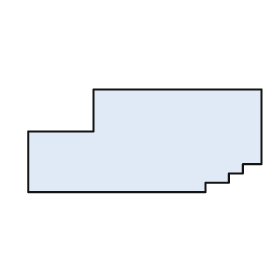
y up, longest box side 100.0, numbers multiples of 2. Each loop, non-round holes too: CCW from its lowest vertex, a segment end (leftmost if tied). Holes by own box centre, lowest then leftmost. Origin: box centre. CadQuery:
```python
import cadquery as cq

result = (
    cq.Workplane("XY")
    .moveTo(-50.0, -22.0)
    .lineTo(26.0, -22.0)
    .lineTo(26.0, -18.0)
    .lineTo(36.0, -18.0)
    .lineTo(36.0, -14.0)
    .lineTo(42.0, -14.0)
    .lineTo(42.0, -10.0)
    .lineTo(50.0, -10.0)
    .lineTo(50.0, 22.0)
    .lineTo(-22.0, 22.0)
    .lineTo(-22.0, 4.0)
    .lineTo(-50.0, 4.0)
    .close()
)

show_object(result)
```